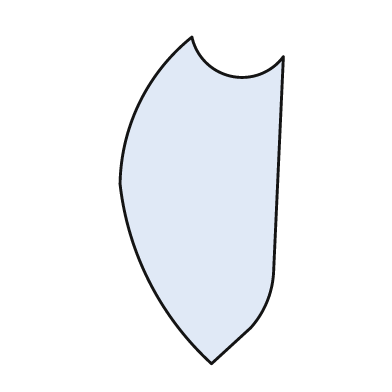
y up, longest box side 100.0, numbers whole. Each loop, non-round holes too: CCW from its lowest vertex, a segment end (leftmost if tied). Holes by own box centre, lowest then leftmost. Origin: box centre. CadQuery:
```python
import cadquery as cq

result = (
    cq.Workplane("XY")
    .moveTo(3.0, -50.0)
    .lineTo(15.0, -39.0)
    .threePointArc((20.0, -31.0), (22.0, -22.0))
    .lineTo(25.0, 44.0)
    .threePointArc((9.0, 38.0), (-3.0, 50.0))
    .threePointArc((-19.0, 30.0), (-25.0, 5.0))
    .threePointArc((-16.0, -25.0), (3.0, -50.0))
    .close()
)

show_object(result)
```